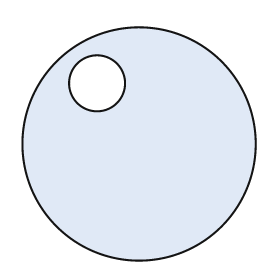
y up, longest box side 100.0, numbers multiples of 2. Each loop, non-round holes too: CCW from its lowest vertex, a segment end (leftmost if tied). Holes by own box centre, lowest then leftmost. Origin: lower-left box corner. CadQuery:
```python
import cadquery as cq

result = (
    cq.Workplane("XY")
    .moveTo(50.0, 50.0)
    .circle(50.0)
    .moveTo(32.0, 76.0)
    .circle(12.0)
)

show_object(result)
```